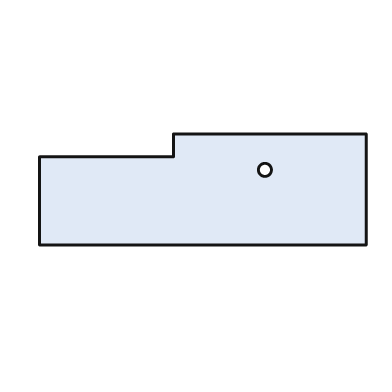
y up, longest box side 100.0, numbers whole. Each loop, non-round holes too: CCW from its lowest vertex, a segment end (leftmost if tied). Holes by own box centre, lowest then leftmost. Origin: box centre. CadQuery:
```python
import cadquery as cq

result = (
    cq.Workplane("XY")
    .moveTo(-50.0, -17.0)
    .lineTo(50.0, -17.0)
    .lineTo(50.0, 17.0)
    .lineTo(-9.0, 17.0)
    .lineTo(-9.0, 10.0)
    .lineTo(-50.0, 10.0)
    .close()
    .moveTo(19.0, 6.0)
    .circle(2.0)
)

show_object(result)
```